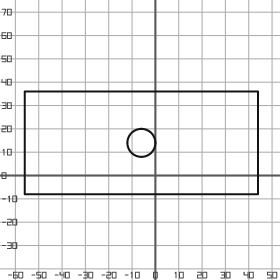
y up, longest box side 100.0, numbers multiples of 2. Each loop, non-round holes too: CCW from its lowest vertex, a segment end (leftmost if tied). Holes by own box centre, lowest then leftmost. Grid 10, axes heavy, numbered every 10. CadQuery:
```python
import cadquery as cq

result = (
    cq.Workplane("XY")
    .moveTo(-56.0, -8.0)
    .lineTo(44.0, -8.0)
    .lineTo(44.0, 36.0)
    .lineTo(-56.0, 36.0)
    .close()
    .moveTo(-6.0, 14.0)
    .circle(6.0)
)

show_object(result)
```